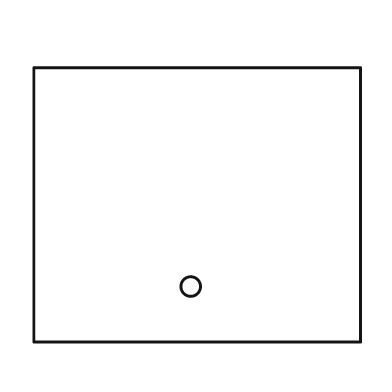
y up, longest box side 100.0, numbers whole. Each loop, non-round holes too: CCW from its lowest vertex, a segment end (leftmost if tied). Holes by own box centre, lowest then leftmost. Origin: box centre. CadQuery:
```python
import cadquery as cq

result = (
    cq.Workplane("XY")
    .moveTo(-50.0, -42.0)
    .lineTo(50.0, -42.0)
    .lineTo(50.0, 42.0)
    .lineTo(-50.0, 42.0)
    .close()
    .moveTo(-2.0, -25.0)
    .circle(3.0)
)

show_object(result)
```